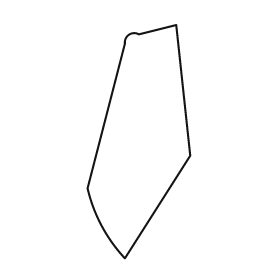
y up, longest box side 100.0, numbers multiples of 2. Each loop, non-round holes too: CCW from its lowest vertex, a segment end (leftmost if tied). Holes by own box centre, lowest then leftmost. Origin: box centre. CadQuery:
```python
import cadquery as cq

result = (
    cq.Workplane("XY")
    .moveTo(-6.0, -50.0)
    .lineTo(22.0, -6.0)
    .lineTo(16.0, 50.0)
    .lineTo(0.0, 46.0)
    .threePointArc((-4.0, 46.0), (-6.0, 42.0))
    .lineTo(-22.0, -20.0)
    .threePointArc((-16.0, -36.0), (-6.0, -50.0))
    .close()
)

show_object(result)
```